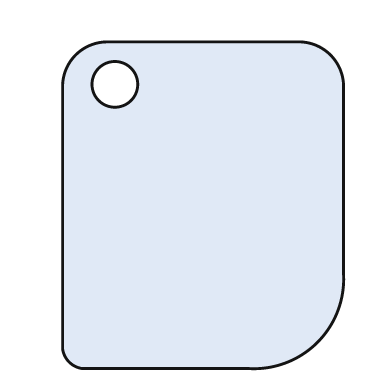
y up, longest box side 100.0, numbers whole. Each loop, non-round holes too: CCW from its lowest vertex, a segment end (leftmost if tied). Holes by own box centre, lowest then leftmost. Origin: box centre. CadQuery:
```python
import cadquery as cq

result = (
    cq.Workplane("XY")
    .moveTo(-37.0, -50.0)
    .lineTo(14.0, -50.0)
    .threePointArc((35.0, -42.0), (43.0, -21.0))
    .lineTo(43.0, 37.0)
    .threePointArc((39.0, 46.0), (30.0, 50.0))
    .lineTo(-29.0, 50.0)
    .threePointArc((-39.0, 46.0), (-43.0, 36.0))
    .lineTo(-43.0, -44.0)
    .threePointArc((-41.0, -48.0), (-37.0, -50.0))
    .close()
    .moveTo(-27.0, 37.0)
    .circle(7.0)
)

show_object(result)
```